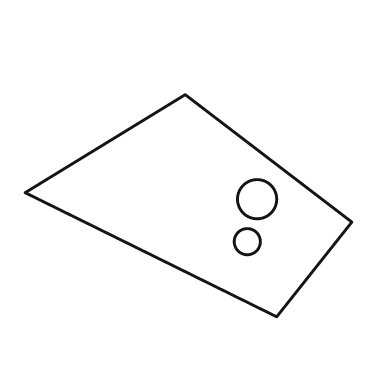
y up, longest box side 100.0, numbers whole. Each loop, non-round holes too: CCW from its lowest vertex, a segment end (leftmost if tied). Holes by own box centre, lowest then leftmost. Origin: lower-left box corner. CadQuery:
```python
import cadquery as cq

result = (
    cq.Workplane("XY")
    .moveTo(77.0, 0.0)
    .lineTo(100.0, 29.0)
    .lineTo(49.0, 68.0)
    .lineTo(0.0, 38.0)
    .close()
    .moveTo(68.0, 23.0)
    .circle(4.0)
    .moveTo(71.0, 36.0)
    .circle(6.0)
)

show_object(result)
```